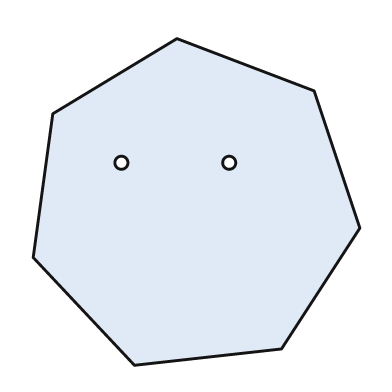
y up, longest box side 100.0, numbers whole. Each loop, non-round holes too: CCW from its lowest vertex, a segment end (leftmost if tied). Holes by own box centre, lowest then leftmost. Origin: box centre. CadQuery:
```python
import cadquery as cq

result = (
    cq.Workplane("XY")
    .moveTo(-19.0, -50.0)
    .lineTo(26.0, -45.0)
    .lineTo(50.0, -8.0)
    .lineTo(36.0, 34.0)
    .lineTo(-6.0, 50.0)
    .lineTo(-44.0, 27.0)
    .lineTo(-50.0, -17.0)
    .close()
    .moveTo(-23.0, 12.0)
    .circle(2.0)
    .moveTo(10.0, 12.0)
    .circle(2.0)
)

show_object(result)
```